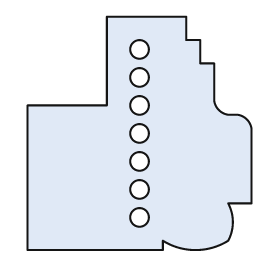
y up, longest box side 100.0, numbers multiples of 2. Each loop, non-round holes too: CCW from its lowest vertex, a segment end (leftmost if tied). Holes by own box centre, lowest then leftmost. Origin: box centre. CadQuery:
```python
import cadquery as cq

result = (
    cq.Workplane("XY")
    .moveTo(-48.0, -50.0)
    .lineTo(10.0, -50.0)
    .lineTo(10.0, -46.0)
    .threePointArc((24.0, -50.0), (38.0, -46.0))
    .threePointArc((40.0, -38.0), (38.0, -30.0))
    .lineTo(48.0, -30.0)
    .lineTo(48.0, 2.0)
    .threePointArc((46.0, 6.0), (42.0, 8.0))
    .lineTo(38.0, 8.0)
    .threePointArc((34.0, 10.0), (32.0, 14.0))
    .lineTo(32.0, 30.0)
    .lineTo(26.0, 30.0)
    .lineTo(26.0, 40.0)
    .lineTo(20.0, 40.0)
    .lineTo(20.0, 50.0)
    .lineTo(-14.0, 50.0)
    .lineTo(-14.0, 12.0)
    .lineTo(-48.0, 12.0)
    .close()
    .moveTo(0.0, -36.0)
    .circle(4.0)
    .moveTo(0.0, -24.0)
    .circle(4.0)
    .moveTo(0.0, -12.0)
    .circle(4.0)
    .moveTo(0.0, 0.0)
    .circle(4.0)
    .moveTo(0.0, 12.0)
    .circle(4.0)
    .moveTo(0.0, 24.0)
    .circle(4.0)
    .moveTo(0.0, 36.0)
    .circle(4.0)
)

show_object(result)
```